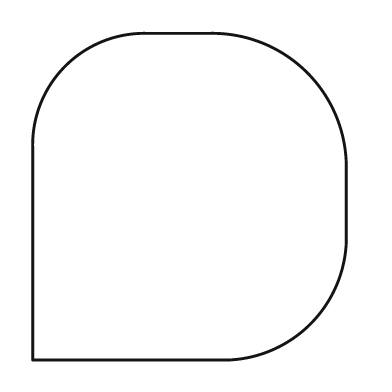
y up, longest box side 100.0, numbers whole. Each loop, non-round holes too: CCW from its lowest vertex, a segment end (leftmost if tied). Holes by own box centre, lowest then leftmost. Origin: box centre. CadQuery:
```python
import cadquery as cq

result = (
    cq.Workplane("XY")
    .moveTo(-48.0, -50.0)
    .lineTo(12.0, -50.0)
    .threePointArc((37.0, -39.0), (48.0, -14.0))
    .lineTo(48.0, 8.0)
    .threePointArc((36.0, 38.0), (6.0, 50.0))
    .lineTo(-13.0, 50.0)
    .threePointArc((-38.0, 40.0), (-48.0, 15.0))
    .close()
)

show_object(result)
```